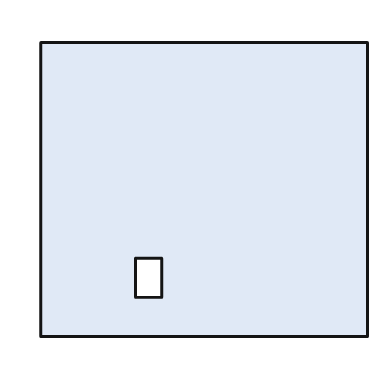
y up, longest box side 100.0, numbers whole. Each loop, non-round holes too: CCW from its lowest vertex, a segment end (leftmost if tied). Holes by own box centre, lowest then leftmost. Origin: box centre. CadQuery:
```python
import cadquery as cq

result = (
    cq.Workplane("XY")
    .moveTo(-50.0, -45.0)
    .lineTo(50.0, -45.0)
    .lineTo(50.0, 45.0)
    .lineTo(-50.0, 45.0)
    .close()
    .moveTo(-21.0, -33.0)
    .lineTo(-13.0, -33.0)
    .lineTo(-13.0, -21.0)
    .lineTo(-21.0, -21.0)
    .close()
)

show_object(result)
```